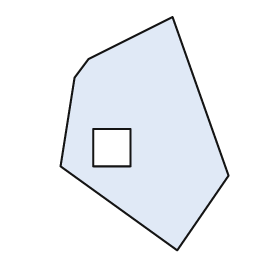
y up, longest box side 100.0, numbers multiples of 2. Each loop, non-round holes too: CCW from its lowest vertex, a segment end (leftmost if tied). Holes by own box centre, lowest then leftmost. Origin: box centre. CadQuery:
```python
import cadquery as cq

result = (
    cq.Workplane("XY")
    .moveTo(14.0, -50.0)
    .lineTo(36.0, -18.0)
    .lineTo(12.0, 50.0)
    .lineTo(-24.0, 32.0)
    .lineTo(-30.0, 24.0)
    .lineTo(-36.0, -14.0)
    .close()
    .moveTo(-22.0, -14.0)
    .lineTo(-6.0, -14.0)
    .lineTo(-6.0, 2.0)
    .lineTo(-22.0, 2.0)
    .close()
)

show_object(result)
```